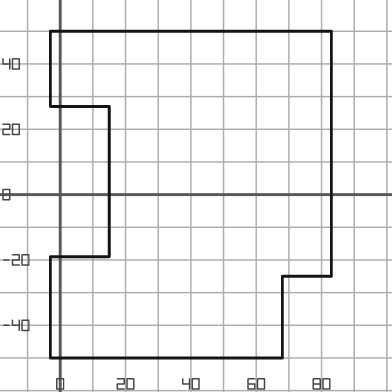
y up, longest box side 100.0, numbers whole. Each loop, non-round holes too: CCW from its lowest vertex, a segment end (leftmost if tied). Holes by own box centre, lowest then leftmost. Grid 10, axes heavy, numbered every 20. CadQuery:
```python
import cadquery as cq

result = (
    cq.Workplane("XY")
    .moveTo(-3.0, -50.0)
    .lineTo(68.0, -50.0)
    .lineTo(68.0, -25.0)
    .lineTo(83.0, -25.0)
    .lineTo(83.0, 50.0)
    .lineTo(-3.0, 50.0)
    .lineTo(-3.0, 27.0)
    .lineTo(15.0, 27.0)
    .lineTo(15.0, -19.0)
    .lineTo(-3.0, -19.0)
    .close()
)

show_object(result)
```